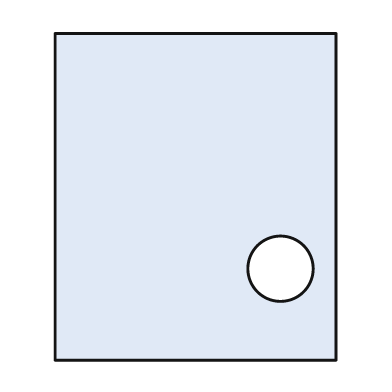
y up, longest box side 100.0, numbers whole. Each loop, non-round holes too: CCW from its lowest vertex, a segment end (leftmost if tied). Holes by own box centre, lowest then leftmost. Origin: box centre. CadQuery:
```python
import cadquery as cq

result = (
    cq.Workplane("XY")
    .moveTo(-43.0, -50.0)
    .lineTo(43.0, -50.0)
    .lineTo(43.0, 50.0)
    .lineTo(-43.0, 50.0)
    .close()
    .moveTo(26.0, -22.0)
    .circle(10.0)
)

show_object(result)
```